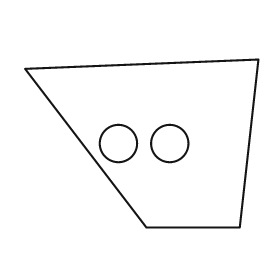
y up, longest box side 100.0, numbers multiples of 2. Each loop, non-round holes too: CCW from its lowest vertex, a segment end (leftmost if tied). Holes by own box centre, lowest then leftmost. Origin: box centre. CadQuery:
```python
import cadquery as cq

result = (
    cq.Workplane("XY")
    .moveTo(2.0, -36.0)
    .lineTo(42.0, -36.0)
    .lineTo(50.0, 36.0)
    .lineTo(-50.0, 32.0)
    .close()
    .moveTo(-10.0, 0.0)
    .circle(8.0)
    .moveTo(12.0, 0.0)
    .circle(8.0)
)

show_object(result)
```